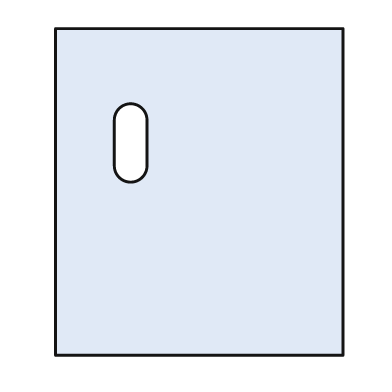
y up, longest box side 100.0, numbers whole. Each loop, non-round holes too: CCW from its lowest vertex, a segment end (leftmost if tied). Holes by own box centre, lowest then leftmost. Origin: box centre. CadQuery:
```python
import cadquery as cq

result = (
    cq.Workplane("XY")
    .moveTo(-44.0, -50.0)
    .lineTo(44.0, -50.0)
    .lineTo(44.0, 50.0)
    .lineTo(-44.0, 50.0)
    .close()
    .moveTo(-26.0, 8.0)
    .threePointArc((-21.0, 3.0), (-16.0, 8.0))
    .lineTo(-16.0, 22.0)
    .threePointArc((-21.0, 27.0), (-26.0, 22.0))
    .close()
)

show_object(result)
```